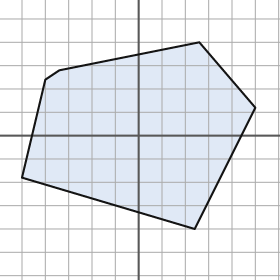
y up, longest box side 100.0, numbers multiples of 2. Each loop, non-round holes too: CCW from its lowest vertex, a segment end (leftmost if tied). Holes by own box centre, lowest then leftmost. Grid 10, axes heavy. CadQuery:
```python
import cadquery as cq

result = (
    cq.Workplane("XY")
    .moveTo(24.0, -40.0)
    .lineTo(50.0, 12.0)
    .lineTo(26.0, 40.0)
    .lineTo(-34.0, 28.0)
    .lineTo(-40.0, 24.0)
    .lineTo(-50.0, -18.0)
    .close()
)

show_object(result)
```